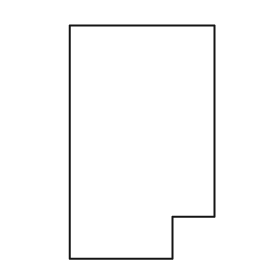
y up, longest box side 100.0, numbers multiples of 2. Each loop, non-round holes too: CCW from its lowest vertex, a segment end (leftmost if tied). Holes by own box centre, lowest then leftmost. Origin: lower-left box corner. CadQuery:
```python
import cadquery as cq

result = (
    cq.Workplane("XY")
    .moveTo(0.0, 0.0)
    .lineTo(44.0, 0.0)
    .lineTo(44.0, 18.0)
    .lineTo(62.0, 18.0)
    .lineTo(62.0, 100.0)
    .lineTo(0.0, 100.0)
    .close()
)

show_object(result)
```